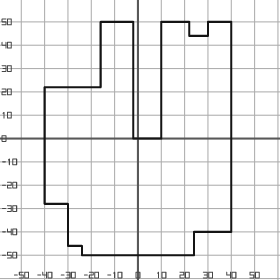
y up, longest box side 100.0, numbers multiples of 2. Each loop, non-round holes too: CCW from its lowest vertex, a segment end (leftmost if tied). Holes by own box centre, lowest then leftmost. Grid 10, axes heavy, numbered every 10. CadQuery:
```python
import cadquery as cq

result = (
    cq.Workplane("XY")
    .moveTo(-24.0, -50.0)
    .lineTo(24.0, -50.0)
    .lineTo(24.0, -40.0)
    .lineTo(40.0, -40.0)
    .lineTo(40.0, 50.0)
    .lineTo(30.0, 50.0)
    .lineTo(30.0, 44.0)
    .lineTo(22.0, 44.0)
    .lineTo(22.0, 50.0)
    .lineTo(10.0, 50.0)
    .lineTo(10.0, 0.0)
    .lineTo(-2.0, 0.0)
    .lineTo(-2.0, 50.0)
    .lineTo(-16.0, 50.0)
    .lineTo(-16.0, 22.0)
    .lineTo(-40.0, 22.0)
    .lineTo(-40.0, -28.0)
    .lineTo(-30.0, -28.0)
    .lineTo(-30.0, -46.0)
    .lineTo(-24.0, -46.0)
    .close()
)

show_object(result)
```